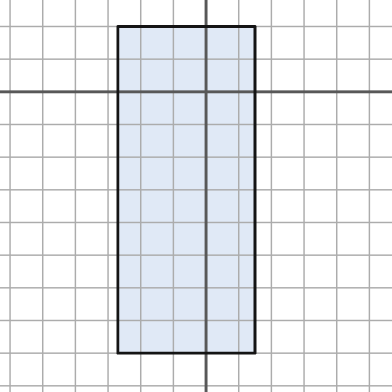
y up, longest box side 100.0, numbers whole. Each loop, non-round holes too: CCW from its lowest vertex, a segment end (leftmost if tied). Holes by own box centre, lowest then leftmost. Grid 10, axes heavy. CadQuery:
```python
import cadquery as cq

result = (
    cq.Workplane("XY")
    .moveTo(-27.0, -80.0)
    .lineTo(15.0, -80.0)
    .lineTo(15.0, 20.0)
    .lineTo(-27.0, 20.0)
    .close()
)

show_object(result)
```